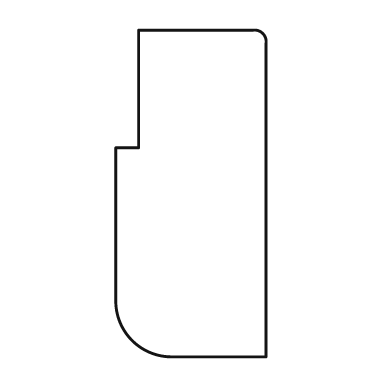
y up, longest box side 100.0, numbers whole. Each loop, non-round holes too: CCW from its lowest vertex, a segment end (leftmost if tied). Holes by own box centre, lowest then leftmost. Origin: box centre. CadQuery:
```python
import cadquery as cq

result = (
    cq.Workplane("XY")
    .moveTo(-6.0, -50.0)
    .lineTo(23.0, -50.0)
    .lineTo(23.0, 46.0)
    .threePointArc((22.0, 49.0), (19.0, 50.0))
    .lineTo(-16.0, 50.0)
    .lineTo(-16.0, 14.0)
    .lineTo(-23.0, 14.0)
    .lineTo(-23.0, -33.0)
    .threePointArc((-18.0, -45.0), (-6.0, -50.0))
    .close()
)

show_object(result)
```